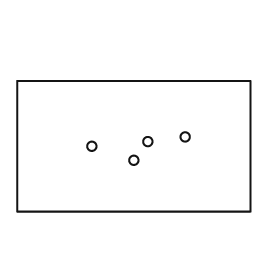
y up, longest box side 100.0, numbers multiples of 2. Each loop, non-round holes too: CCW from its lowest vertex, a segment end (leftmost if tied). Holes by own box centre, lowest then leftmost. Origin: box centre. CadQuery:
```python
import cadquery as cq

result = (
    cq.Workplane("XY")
    .moveTo(-50.0, -28.0)
    .lineTo(50.0, -28.0)
    .lineTo(50.0, 28.0)
    .lineTo(-50.0, 28.0)
    .close()
    .moveTo(0.0, -6.0)
    .circle(2.0)
    .moveTo(-18.0, 0.0)
    .circle(2.0)
    .moveTo(6.0, 2.0)
    .circle(2.0)
    .moveTo(22.0, 4.0)
    .circle(2.0)
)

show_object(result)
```